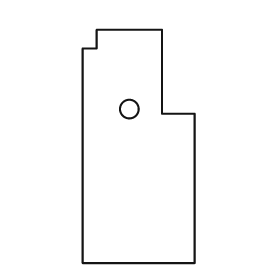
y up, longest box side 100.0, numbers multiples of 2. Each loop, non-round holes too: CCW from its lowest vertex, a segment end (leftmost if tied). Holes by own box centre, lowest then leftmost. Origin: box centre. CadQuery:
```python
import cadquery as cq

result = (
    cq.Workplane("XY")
    .moveTo(-24.0, -50.0)
    .lineTo(24.0, -50.0)
    .lineTo(24.0, 14.0)
    .lineTo(10.0, 14.0)
    .lineTo(10.0, 50.0)
    .lineTo(-18.0, 50.0)
    .lineTo(-18.0, 42.0)
    .lineTo(-24.0, 42.0)
    .close()
    .moveTo(-4.0, 16.0)
    .circle(4.0)
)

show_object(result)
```